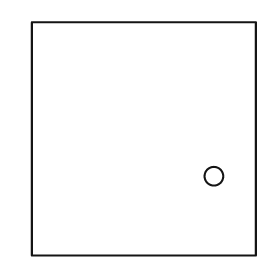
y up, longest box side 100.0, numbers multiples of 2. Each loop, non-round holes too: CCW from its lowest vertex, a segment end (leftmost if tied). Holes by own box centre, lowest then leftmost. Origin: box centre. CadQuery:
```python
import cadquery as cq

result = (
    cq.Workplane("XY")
    .moveTo(-48.0, -50.0)
    .lineTo(48.0, -50.0)
    .lineTo(48.0, 50.0)
    .lineTo(-48.0, 50.0)
    .close()
    .moveTo(30.0, -16.0)
    .circle(4.0)
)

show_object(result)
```